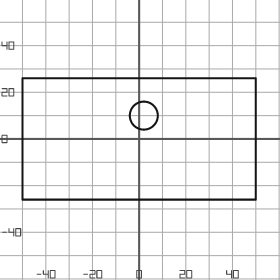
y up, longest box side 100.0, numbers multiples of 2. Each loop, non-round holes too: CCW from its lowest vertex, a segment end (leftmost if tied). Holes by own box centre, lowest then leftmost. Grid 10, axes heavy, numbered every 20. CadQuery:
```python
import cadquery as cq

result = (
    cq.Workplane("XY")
    .moveTo(-50.0, -26.0)
    .lineTo(50.0, -26.0)
    .lineTo(50.0, 26.0)
    .lineTo(-50.0, 26.0)
    .close()
    .moveTo(2.0, 10.0)
    .circle(6.0)
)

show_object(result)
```